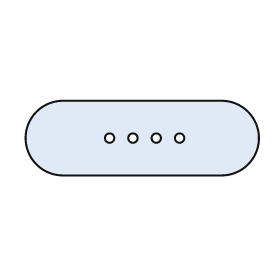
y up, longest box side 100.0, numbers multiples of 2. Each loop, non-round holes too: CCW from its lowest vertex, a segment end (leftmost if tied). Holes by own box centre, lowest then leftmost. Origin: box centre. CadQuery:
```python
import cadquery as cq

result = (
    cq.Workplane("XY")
    .moveTo(-34.0, -16.0)
    .lineTo(34.0, -16.0)
    .threePointArc((50.0, 0.0), (34.0, 16.0))
    .lineTo(-34.0, 16.0)
    .threePointArc((-50.0, 0.0), (-34.0, -16.0))
    .close()
    .moveTo(-14.0, 0.0)
    .circle(2.0)
    .moveTo(-4.0, 0.0)
    .circle(2.0)
    .moveTo(6.0, 0.0)
    .circle(2.0)
    .moveTo(16.0, 0.0)
    .circle(2.0)
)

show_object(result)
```